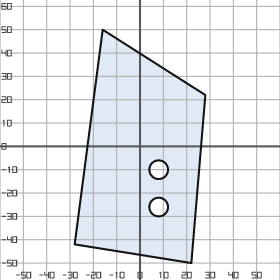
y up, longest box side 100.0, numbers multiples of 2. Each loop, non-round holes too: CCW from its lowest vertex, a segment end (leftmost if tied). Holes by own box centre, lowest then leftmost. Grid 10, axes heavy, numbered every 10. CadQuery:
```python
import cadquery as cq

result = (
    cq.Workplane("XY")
    .moveTo(22.0, -50.0)
    .lineTo(28.0, 22.0)
    .lineTo(-16.0, 50.0)
    .lineTo(-28.0, -42.0)
    .close()
    .moveTo(8.0, -26.0)
    .circle(4.0)
    .moveTo(8.0, -10.0)
    .circle(4.0)
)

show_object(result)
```